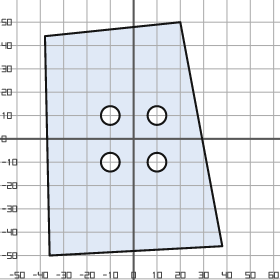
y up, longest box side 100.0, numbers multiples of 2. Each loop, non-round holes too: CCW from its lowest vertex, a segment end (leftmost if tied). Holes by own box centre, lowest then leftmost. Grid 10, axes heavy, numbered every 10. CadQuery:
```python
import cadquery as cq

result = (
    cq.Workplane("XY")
    .moveTo(-36.0, -50.0)
    .lineTo(38.0, -46.0)
    .lineTo(20.0, 50.0)
    .lineTo(-38.0, 44.0)
    .close()
    .moveTo(-10.0, -10.0)
    .circle(4.0)
    .moveTo(10.0, -10.0)
    .circle(4.0)
    .moveTo(-10.0, 10.0)
    .circle(4.0)
    .moveTo(10.0, 10.0)
    .circle(4.0)
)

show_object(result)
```